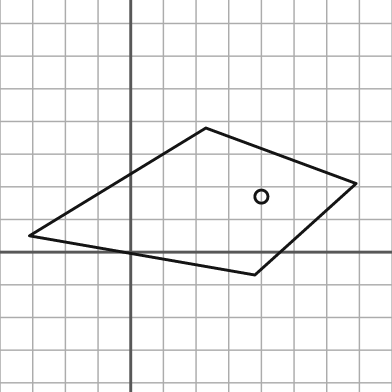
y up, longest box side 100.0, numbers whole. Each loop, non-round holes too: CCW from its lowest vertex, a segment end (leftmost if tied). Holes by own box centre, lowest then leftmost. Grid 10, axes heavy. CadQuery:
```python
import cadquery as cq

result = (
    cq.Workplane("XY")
    .moveTo(38.0, -7.0)
    .lineTo(69.0, 21.0)
    .lineTo(23.0, 38.0)
    .lineTo(-31.0, 5.0)
    .close()
    .moveTo(40.0, 17.0)
    .circle(2.0)
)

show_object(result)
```